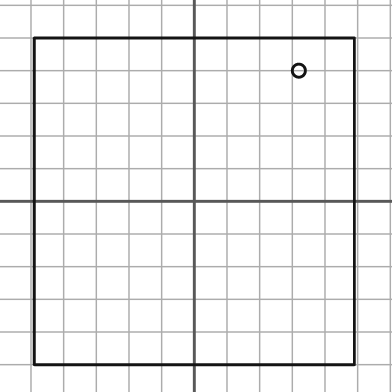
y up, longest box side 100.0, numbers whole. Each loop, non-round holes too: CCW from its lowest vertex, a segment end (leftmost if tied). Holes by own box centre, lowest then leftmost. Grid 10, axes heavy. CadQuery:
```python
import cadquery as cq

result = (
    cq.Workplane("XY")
    .moveTo(-49.0, -50.0)
    .lineTo(49.0, -50.0)
    .lineTo(49.0, 50.0)
    .lineTo(-49.0, 50.0)
    .close()
    .moveTo(32.0, 40.0)
    .circle(2.0)
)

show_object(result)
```